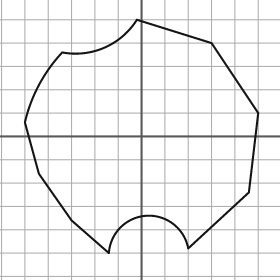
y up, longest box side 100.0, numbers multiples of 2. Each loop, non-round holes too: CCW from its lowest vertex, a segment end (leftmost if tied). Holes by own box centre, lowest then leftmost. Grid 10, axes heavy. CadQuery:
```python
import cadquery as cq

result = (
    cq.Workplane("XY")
    .moveTo(-14.0, -50.0)
    .threePointArc((2.0, -34.0), (20.0, -48.0))
    .lineTo(46.0, -24.0)
    .lineTo(50.0, 10.0)
    .lineTo(30.0, 40.0)
    .lineTo(-2.0, 50.0)
    .threePointArc((-16.0, 38.0), (-34.0, 36.0))
    .threePointArc((-44.0, 22.0), (-50.0, 6.0))
    .lineTo(-44.0, -16.0)
    .lineTo(-30.0, -36.0)
    .close()
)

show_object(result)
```